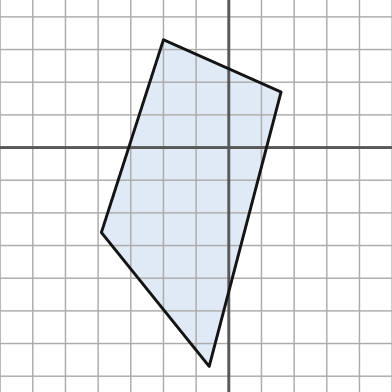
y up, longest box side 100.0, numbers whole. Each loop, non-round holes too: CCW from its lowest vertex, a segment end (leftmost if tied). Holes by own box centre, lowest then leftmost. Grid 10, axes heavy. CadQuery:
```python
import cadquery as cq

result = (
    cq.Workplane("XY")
    .moveTo(-6.0, -67.0)
    .lineTo(16.0, 17.0)
    .lineTo(-20.0, 33.0)
    .lineTo(-39.0, -26.0)
    .close()
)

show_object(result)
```